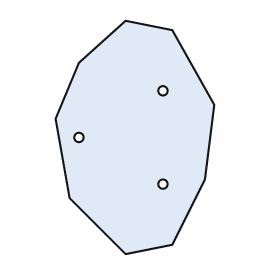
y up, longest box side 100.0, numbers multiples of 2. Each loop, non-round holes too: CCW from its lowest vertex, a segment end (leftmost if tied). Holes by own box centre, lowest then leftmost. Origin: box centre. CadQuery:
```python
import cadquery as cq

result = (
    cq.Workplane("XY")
    .moveTo(-4.0, -50.0)
    .lineTo(16.0, -46.0)
    .lineTo(30.0, -18.0)
    .lineTo(34.0, 14.0)
    .lineTo(16.0, 46.0)
    .lineTo(-4.0, 50.0)
    .lineTo(-24.0, 32.0)
    .lineTo(-34.0, 8.0)
    .lineTo(-28.0, -26.0)
    .close()
    .moveTo(12.0, -20.0)
    .circle(2.0)
    .moveTo(-24.0, 0.0)
    .circle(2.0)
    .moveTo(12.0, 20.0)
    .circle(2.0)
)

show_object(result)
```